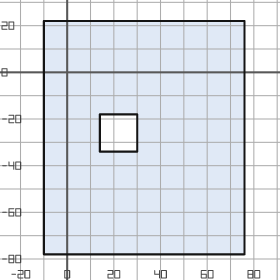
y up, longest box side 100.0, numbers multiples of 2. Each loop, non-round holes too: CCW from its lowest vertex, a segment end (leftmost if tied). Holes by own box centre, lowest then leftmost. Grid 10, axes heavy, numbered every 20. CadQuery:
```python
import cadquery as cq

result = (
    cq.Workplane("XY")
    .moveTo(-10.0, -78.0)
    .lineTo(76.0, -78.0)
    .lineTo(76.0, 22.0)
    .lineTo(-10.0, 22.0)
    .close()
    .moveTo(14.0, -34.0)
    .lineTo(30.0, -34.0)
    .lineTo(30.0, -18.0)
    .lineTo(14.0, -18.0)
    .close()
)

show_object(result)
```